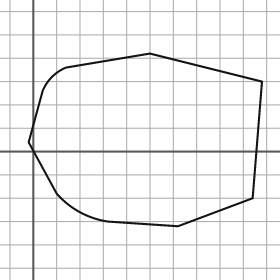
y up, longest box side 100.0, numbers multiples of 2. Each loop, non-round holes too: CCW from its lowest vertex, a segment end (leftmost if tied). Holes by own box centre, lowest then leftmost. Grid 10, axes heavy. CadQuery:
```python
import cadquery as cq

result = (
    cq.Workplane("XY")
    .moveTo(62.0, -32.0)
    .lineTo(94.0, -20.0)
    .lineTo(98.0, 30.0)
    .lineTo(50.0, 42.0)
    .lineTo(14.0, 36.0)
    .threePointArc((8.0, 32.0), (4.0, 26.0))
    .lineTo(-2.0, 4.0)
    .lineTo(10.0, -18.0)
    .threePointArc((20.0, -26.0), (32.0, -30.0))
    .close()
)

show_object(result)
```